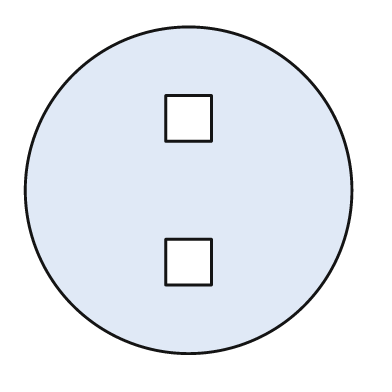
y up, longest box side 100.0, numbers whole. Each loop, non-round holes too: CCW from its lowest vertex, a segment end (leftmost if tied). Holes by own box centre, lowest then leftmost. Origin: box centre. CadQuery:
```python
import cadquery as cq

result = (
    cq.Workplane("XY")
    .moveTo(0.0, 0.0)
    .circle(50.0)
    .moveTo(-7.0, -29.0)
    .lineTo(7.0, -29.0)
    .lineTo(7.0, -15.0)
    .lineTo(-7.0, -15.0)
    .close()
    .moveTo(-7.0, 15.0)
    .lineTo(7.0, 15.0)
    .lineTo(7.0, 29.0)
    .lineTo(-7.0, 29.0)
    .close()
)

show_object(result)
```